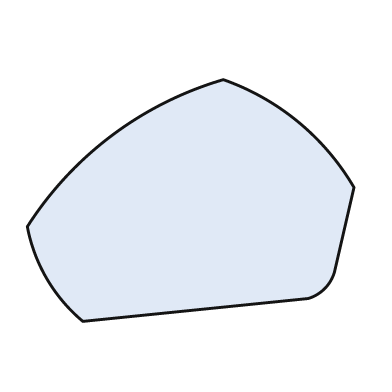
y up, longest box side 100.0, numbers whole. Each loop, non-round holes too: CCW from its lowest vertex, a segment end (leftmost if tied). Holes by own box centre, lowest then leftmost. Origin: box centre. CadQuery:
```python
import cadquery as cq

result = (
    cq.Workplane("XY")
    .moveTo(-33.0, -37.0)
    .lineTo(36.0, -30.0)
    .threePointArc((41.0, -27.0), (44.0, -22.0))
    .lineTo(50.0, 4.0)
    .threePointArc((33.0, 24.0), (10.0, 37.0))
    .threePointArc((-24.0, 20.0), (-50.0, -8.0))
    .threePointArc((-44.0, -24.0), (-33.0, -37.0))
    .close()
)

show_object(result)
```